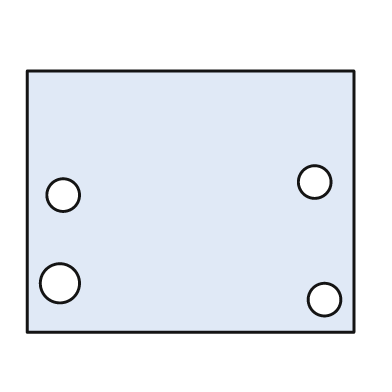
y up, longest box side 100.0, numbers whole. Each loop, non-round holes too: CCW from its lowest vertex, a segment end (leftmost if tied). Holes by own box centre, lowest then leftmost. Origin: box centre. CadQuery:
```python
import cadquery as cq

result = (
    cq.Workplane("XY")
    .moveTo(-50.0, -40.0)
    .lineTo(50.0, -40.0)
    .lineTo(50.0, 40.0)
    .lineTo(-50.0, 40.0)
    .close()
    .moveTo(41.0, -30.0)
    .circle(5.0)
    .moveTo(-40.0, -25.0)
    .circle(6.0)
    .moveTo(-39.0, 2.0)
    .circle(5.0)
    .moveTo(38.0, 6.0)
    .circle(5.0)
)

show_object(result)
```